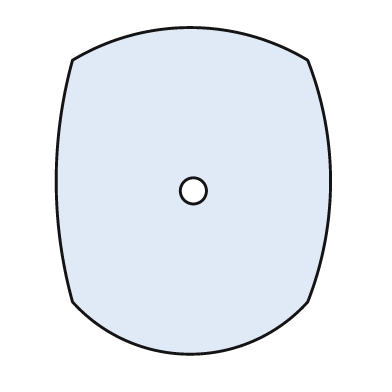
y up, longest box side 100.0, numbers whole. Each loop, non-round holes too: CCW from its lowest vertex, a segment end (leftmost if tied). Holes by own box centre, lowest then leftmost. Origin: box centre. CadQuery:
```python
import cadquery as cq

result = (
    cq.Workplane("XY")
    .moveTo(-37.0, -34.0)
    .threePointArc((-1.0, -50.0), (35.0, -34.0))
    .threePointArc((42.0, 3.0), (35.0, 40.0))
    .threePointArc((-1.0, 50.0), (-37.0, 40.0))
    .threePointArc((-42.0, 3.0), (-37.0, -34.0))
    .close()
    .moveTo(0.0, 0.0)
    .circle(4.0)
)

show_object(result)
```